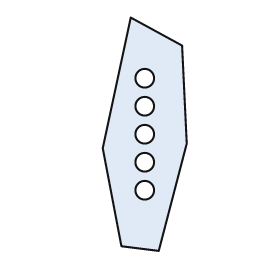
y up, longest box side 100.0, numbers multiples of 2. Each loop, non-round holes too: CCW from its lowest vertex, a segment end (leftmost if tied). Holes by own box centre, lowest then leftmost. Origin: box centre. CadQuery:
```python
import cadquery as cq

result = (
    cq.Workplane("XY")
    .moveTo(6.0, -50.0)
    .lineTo(18.0, -4.0)
    .lineTo(16.0, 38.0)
    .lineTo(-6.0, 50.0)
    .lineTo(-18.0, -6.0)
    .lineTo(-10.0, -48.0)
    .close()
    .moveTo(0.0, -24.0)
    .circle(4.0)
    .moveTo(0.0, -12.0)
    .circle(4.0)
    .moveTo(0.0, 0.0)
    .circle(4.0)
    .moveTo(0.0, 12.0)
    .circle(4.0)
    .moveTo(0.0, 24.0)
    .circle(4.0)
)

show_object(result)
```